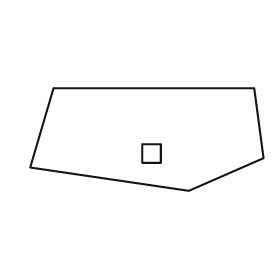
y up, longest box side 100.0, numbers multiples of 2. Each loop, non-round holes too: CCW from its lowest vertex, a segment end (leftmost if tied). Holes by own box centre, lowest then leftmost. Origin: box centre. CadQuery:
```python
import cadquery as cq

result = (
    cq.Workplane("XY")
    .moveTo(18.0, -22.0)
    .lineTo(50.0, -8.0)
    .lineTo(46.0, 22.0)
    .lineTo(-40.0, 22.0)
    .lineTo(-50.0, -12.0)
    .close()
    .moveTo(-2.0, -10.0)
    .lineTo(6.0, -10.0)
    .lineTo(6.0, -2.0)
    .lineTo(-2.0, -2.0)
    .close()
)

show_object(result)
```